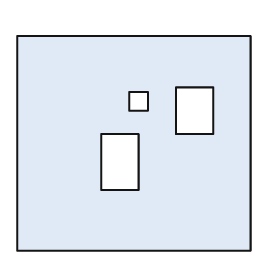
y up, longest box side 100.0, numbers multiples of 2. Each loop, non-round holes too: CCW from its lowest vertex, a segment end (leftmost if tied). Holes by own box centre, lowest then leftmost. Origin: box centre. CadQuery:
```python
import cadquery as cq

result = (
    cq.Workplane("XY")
    .moveTo(-50.0, -46.0)
    .lineTo(50.0, -46.0)
    .lineTo(50.0, 46.0)
    .lineTo(-50.0, 46.0)
    .close()
    .moveTo(-14.0, -20.0)
    .lineTo(2.0, -20.0)
    .lineTo(2.0, 4.0)
    .lineTo(-14.0, 4.0)
    .close()
    .moveTo(18.0, 4.0)
    .lineTo(34.0, 4.0)
    .lineTo(34.0, 24.0)
    .lineTo(18.0, 24.0)
    .close()
    .moveTo(-2.0, 14.0)
    .lineTo(6.0, 14.0)
    .lineTo(6.0, 22.0)
    .lineTo(-2.0, 22.0)
    .close()
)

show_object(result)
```